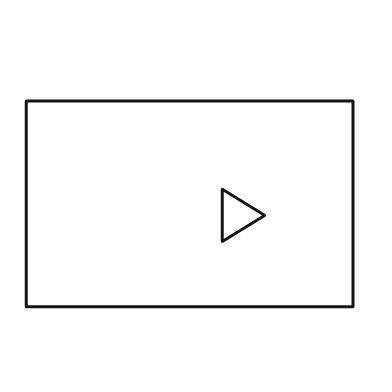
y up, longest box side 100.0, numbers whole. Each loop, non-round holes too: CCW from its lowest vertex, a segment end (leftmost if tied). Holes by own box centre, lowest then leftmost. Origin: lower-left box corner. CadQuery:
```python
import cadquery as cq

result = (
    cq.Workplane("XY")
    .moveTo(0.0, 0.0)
    .lineTo(100.0, 0.0)
    .lineTo(100.0, 63.0)
    .lineTo(0.0, 63.0)
    .close()
    .moveTo(60.0, 20.0)
    .lineTo(73.0, 28.0)
    .lineTo(60.0, 36.0)
    .close()
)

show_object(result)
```